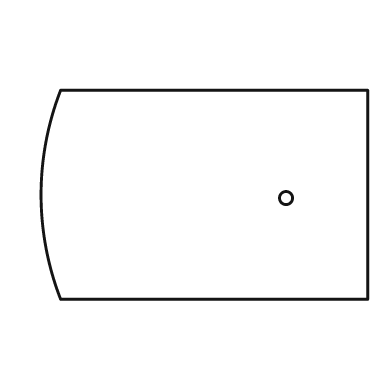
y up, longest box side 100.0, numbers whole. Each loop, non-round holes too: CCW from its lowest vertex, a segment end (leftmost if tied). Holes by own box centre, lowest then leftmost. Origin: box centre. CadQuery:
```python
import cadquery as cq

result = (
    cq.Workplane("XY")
    .moveTo(-44.0, -32.0)
    .lineTo(50.0, -32.0)
    .lineTo(50.0, 32.0)
    .lineTo(-44.0, 32.0)
    .threePointArc((-50.0, 0.0), (-44.0, -32.0))
    .close()
    .moveTo(25.0, -1.0)
    .circle(2.0)
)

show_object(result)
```